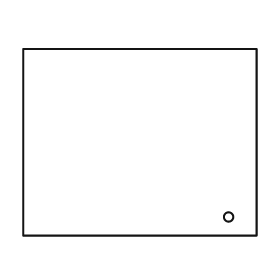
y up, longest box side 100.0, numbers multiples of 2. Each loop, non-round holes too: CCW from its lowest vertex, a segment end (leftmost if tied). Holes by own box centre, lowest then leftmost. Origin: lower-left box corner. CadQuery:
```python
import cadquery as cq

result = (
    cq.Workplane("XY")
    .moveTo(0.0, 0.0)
    .lineTo(100.0, 0.0)
    .lineTo(100.0, 80.0)
    .lineTo(0.0, 80.0)
    .close()
    .moveTo(88.0, 8.0)
    .circle(2.0)
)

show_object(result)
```